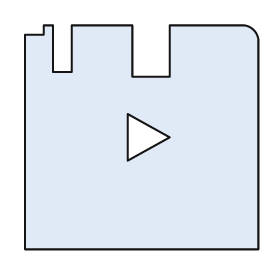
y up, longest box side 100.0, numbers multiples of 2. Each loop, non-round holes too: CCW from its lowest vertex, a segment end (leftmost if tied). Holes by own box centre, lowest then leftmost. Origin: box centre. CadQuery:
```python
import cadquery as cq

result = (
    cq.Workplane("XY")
    .moveTo(-50.0, -48.0)
    .lineTo(50.0, -48.0)
    .lineTo(50.0, 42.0)
    .threePointArc((48.0, 46.0), (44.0, 48.0))
    .lineTo(12.0, 48.0)
    .lineTo(12.0, 26.0)
    .lineTo(-4.0, 26.0)
    .lineTo(-4.0, 48.0)
    .lineTo(-30.0, 48.0)
    .lineTo(-30.0, 28.0)
    .lineTo(-38.0, 28.0)
    .lineTo(-38.0, 48.0)
    .lineTo(-42.0, 48.0)
    .lineTo(-42.0, 44.0)
    .lineTo(-50.0, 44.0)
    .close()
    .moveTo(-6.0, -10.0)
    .lineTo(12.0, 0.0)
    .lineTo(-6.0, 10.0)
    .close()
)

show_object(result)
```